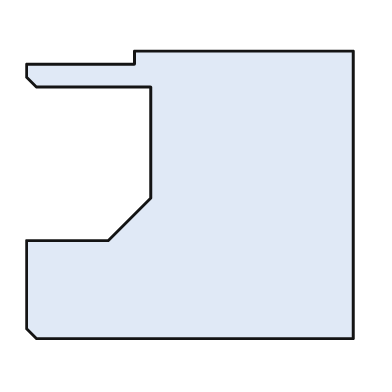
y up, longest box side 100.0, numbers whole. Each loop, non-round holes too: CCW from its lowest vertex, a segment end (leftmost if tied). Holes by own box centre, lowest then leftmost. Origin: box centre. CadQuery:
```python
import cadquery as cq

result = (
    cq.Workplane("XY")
    .moveTo(-47.0, -44.0)
    .lineTo(50.0, -44.0)
    .lineTo(50.0, 44.0)
    .lineTo(-17.0, 44.0)
    .lineTo(-17.0, 40.0)
    .lineTo(-50.0, 40.0)
    .lineTo(-50.0, 36.0)
    .lineTo(-47.0, 33.0)
    .lineTo(-12.0, 33.0)
    .lineTo(-12.0, -1.0)
    .lineTo(-25.0, -14.0)
    .lineTo(-50.0, -14.0)
    .lineTo(-50.0, -41.0)
    .close()
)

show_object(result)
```